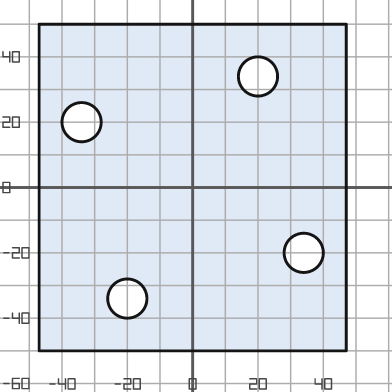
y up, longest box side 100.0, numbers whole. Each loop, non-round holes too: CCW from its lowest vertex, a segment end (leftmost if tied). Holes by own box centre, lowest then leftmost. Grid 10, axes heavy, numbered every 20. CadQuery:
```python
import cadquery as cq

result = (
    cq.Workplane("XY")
    .moveTo(-47.0, -50.0)
    .lineTo(47.0, -50.0)
    .lineTo(47.0, 50.0)
    .lineTo(-47.0, 50.0)
    .close()
    .moveTo(-20.0, -34.0)
    .circle(6.0)
    .moveTo(34.0, -20.0)
    .circle(6.0)
    .moveTo(-34.0, 20.0)
    .circle(6.0)
    .moveTo(20.0, 34.0)
    .circle(6.0)
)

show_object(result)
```